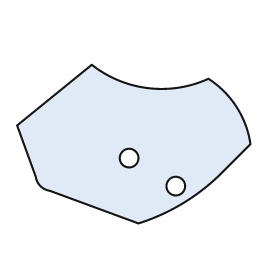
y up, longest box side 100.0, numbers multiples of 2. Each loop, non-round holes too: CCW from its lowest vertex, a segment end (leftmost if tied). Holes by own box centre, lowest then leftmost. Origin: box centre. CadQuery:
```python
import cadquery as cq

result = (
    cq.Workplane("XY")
    .moveTo(2.0, -34.0)
    .threePointArc((20.0, -26.0), (36.0, -14.0))
    .lineTo(50.0, 0.0)
    .threePointArc((44.0, 16.0), (32.0, 28.0))
    .threePointArc((6.0, 24.0), (-18.0, 34.0))
    .lineTo(-50.0, 8.0)
    .lineTo(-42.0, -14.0)
    .threePointArc((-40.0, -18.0), (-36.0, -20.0))
    .close()
    .moveTo(18.0, -18.0)
    .circle(4.0)
    .moveTo(-2.0, -6.0)
    .circle(4.0)
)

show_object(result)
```